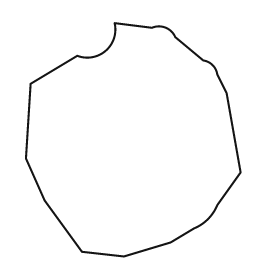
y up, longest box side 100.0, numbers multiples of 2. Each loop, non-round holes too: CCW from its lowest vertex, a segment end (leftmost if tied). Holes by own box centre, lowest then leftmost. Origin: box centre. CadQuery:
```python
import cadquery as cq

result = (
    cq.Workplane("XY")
    .moveTo(-4.0, -50.0)
    .lineTo(16.0, -44.0)
    .lineTo(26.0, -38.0)
    .threePointArc((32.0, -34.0), (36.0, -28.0))
    .lineTo(46.0, -14.0)
    .lineTo(40.0, 20.0)
    .lineTo(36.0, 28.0)
    .threePointArc((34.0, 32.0), (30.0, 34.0))
    .lineTo(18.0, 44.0)
    .threePointArc((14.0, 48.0), (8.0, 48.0))
    .lineTo(-8.0, 50.0)
    .threePointArc((-12.0, 38.0), (-24.0, 36.0))
    .lineTo(-44.0, 24.0)
    .lineTo(-46.0, -8.0)
    .lineTo(-38.0, -26.0)
    .lineTo(-22.0, -48.0)
    .close()
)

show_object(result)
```